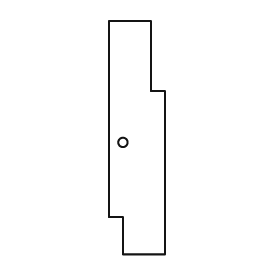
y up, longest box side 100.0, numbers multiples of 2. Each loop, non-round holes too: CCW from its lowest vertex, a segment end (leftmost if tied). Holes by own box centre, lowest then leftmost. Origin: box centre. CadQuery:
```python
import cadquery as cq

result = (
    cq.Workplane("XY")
    .moveTo(-6.0, -50.0)
    .lineTo(12.0, -50.0)
    .lineTo(12.0, 20.0)
    .lineTo(6.0, 20.0)
    .lineTo(6.0, 50.0)
    .lineTo(-12.0, 50.0)
    .lineTo(-12.0, -34.0)
    .lineTo(-6.0, -34.0)
    .close()
    .moveTo(-6.0, -2.0)
    .circle(2.0)
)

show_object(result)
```